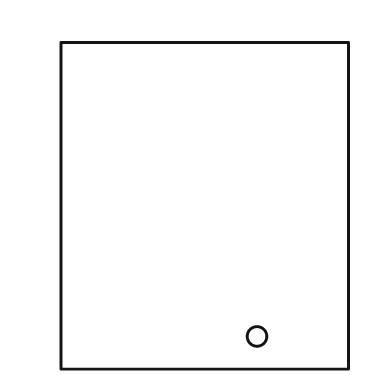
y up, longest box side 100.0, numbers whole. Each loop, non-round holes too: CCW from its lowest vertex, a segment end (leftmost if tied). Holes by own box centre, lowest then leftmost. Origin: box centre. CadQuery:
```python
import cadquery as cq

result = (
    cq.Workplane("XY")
    .moveTo(-44.0, -50.0)
    .lineTo(44.0, -50.0)
    .lineTo(44.0, 50.0)
    .lineTo(-44.0, 50.0)
    .close()
    .moveTo(16.0, -40.0)
    .circle(3.0)
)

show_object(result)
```